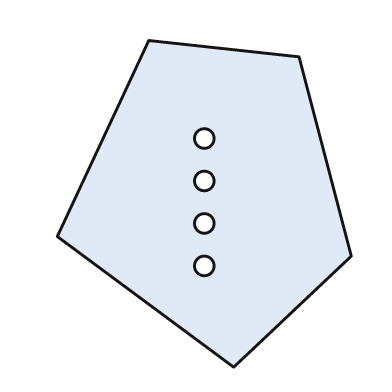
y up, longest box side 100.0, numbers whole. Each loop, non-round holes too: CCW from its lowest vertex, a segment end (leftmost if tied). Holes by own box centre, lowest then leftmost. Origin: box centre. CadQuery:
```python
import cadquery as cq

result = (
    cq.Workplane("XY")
    .moveTo(9.0, -50.0)
    .lineTo(45.0, -16.0)
    .lineTo(29.0, 45.0)
    .lineTo(-17.0, 50.0)
    .lineTo(-45.0, -10.0)
    .close()
    .moveTo(0.0, -19.0)
    .circle(3.0)
    .moveTo(0.0, -6.0)
    .circle(3.0)
    .moveTo(0.0, 7.0)
    .circle(3.0)
    .moveTo(0.0, 20.0)
    .circle(3.0)
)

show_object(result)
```